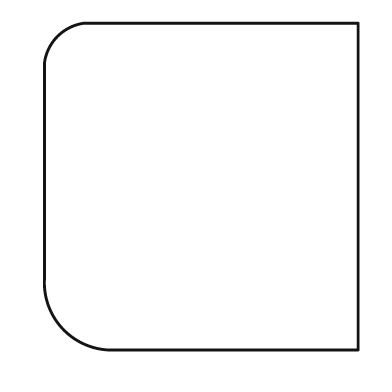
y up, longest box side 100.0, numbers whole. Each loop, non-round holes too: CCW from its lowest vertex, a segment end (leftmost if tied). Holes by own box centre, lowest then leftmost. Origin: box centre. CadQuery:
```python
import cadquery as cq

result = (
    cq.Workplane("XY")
    .moveTo(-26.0, -50.0)
    .lineTo(48.0, -50.0)
    .lineTo(48.0, 50.0)
    .lineTo(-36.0, 50.0)
    .threePointArc((-44.0, 46.0), (-48.0, 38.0))
    .lineTo(-48.0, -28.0)
    .threePointArc((-42.0, -44.0), (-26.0, -50.0))
    .close()
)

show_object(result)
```